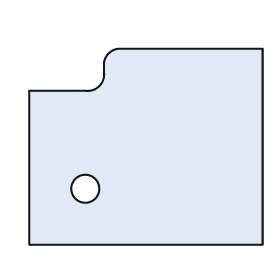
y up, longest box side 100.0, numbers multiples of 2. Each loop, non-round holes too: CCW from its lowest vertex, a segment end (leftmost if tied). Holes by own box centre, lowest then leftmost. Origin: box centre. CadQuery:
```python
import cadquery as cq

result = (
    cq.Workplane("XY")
    .moveTo(-50.0, -42.0)
    .lineTo(50.0, -42.0)
    .lineTo(50.0, 42.0)
    .lineTo(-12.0, 42.0)
    .threePointArc((-16.0, 40.0), (-18.0, 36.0))
    .lineTo(-18.0, 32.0)
    .threePointArc((-20.0, 26.0), (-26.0, 24.0))
    .lineTo(-50.0, 24.0)
    .close()
    .moveTo(-26.0, -18.0)
    .circle(6.0)
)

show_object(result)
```